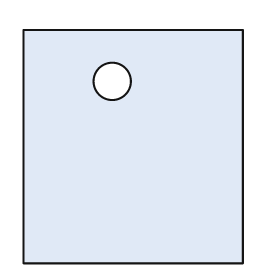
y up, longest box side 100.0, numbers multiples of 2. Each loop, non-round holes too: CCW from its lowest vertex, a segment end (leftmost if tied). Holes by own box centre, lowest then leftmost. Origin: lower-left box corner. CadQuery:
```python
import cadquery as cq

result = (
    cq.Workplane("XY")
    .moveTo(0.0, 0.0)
    .lineTo(94.0, 0.0)
    .lineTo(94.0, 100.0)
    .lineTo(0.0, 100.0)
    .close()
    .moveTo(38.0, 78.0)
    .circle(8.0)
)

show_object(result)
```